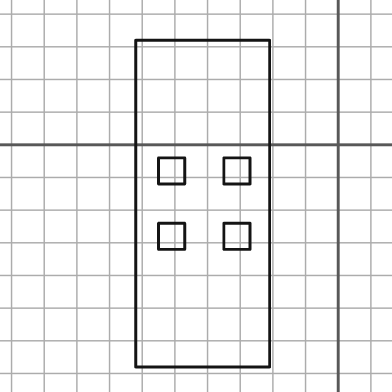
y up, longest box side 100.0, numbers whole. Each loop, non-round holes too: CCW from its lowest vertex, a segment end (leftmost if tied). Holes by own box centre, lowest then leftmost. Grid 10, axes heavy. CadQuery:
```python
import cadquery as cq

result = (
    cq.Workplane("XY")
    .moveTo(-62.0, -68.0)
    .lineTo(-21.0, -68.0)
    .lineTo(-21.0, 32.0)
    .lineTo(-62.0, 32.0)
    .close()
    .moveTo(-55.0, -32.0)
    .lineTo(-47.0, -32.0)
    .lineTo(-47.0, -24.0)
    .lineTo(-55.0, -24.0)
    .close()
    .moveTo(-35.0, -32.0)
    .lineTo(-27.0, -32.0)
    .lineTo(-27.0, -24.0)
    .lineTo(-35.0, -24.0)
    .close()
    .moveTo(-55.0, -12.0)
    .lineTo(-47.0, -12.0)
    .lineTo(-47.0, -4.0)
    .lineTo(-55.0, -4.0)
    .close()
    .moveTo(-35.0, -12.0)
    .lineTo(-27.0, -12.0)
    .lineTo(-27.0, -4.0)
    .lineTo(-35.0, -4.0)
    .close()
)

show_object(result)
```